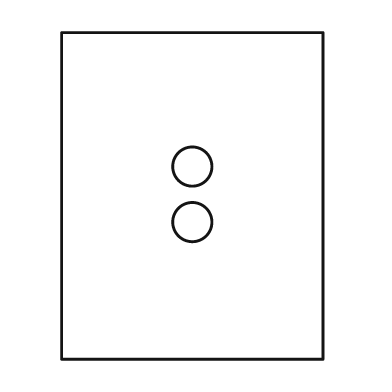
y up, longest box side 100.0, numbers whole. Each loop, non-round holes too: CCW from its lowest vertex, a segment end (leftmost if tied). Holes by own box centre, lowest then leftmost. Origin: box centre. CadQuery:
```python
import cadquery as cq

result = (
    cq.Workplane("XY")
    .moveTo(-40.0, -50.0)
    .lineTo(40.0, -50.0)
    .lineTo(40.0, 50.0)
    .lineTo(-40.0, 50.0)
    .close()
    .moveTo(0.0, -8.0)
    .circle(6.0)
    .moveTo(0.0, 9.0)
    .circle(6.0)
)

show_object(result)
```